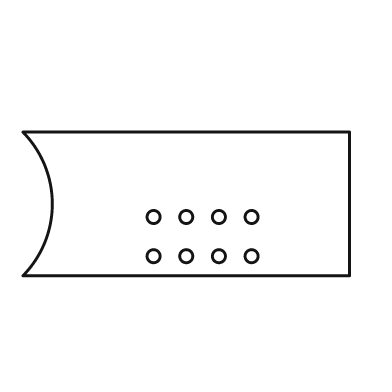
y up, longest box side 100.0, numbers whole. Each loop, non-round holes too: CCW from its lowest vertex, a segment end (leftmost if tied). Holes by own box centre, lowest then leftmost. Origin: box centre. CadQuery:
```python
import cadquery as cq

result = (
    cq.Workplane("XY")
    .moveTo(-50.0, -22.0)
    .lineTo(50.0, -22.0)
    .lineTo(50.0, 22.0)
    .lineTo(-50.0, 22.0)
    .threePointArc((-41.0, 0.0), (-50.0, -22.0))
    .close()
    .moveTo(-10.0, -16.0)
    .circle(2.0)
    .moveTo(0.0, -16.0)
    .circle(2.0)
    .moveTo(10.0, -16.0)
    .circle(2.0)
    .moveTo(20.0, -16.0)
    .circle(2.0)
    .moveTo(-10.0, -4.0)
    .circle(2.0)
    .moveTo(0.0, -4.0)
    .circle(2.0)
    .moveTo(10.0, -4.0)
    .circle(2.0)
    .moveTo(20.0, -4.0)
    .circle(2.0)
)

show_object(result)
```